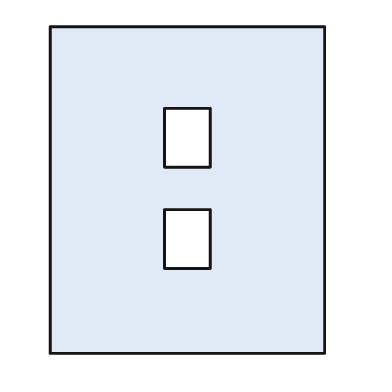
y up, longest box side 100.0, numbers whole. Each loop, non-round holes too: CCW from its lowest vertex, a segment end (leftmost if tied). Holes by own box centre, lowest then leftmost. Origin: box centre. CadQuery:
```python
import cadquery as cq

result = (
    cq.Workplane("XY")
    .moveTo(-42.0, -50.0)
    .lineTo(42.0, -50.0)
    .lineTo(42.0, 50.0)
    .lineTo(-42.0, 50.0)
    .close()
    .moveTo(-7.0, -24.0)
    .lineTo(7.0, -24.0)
    .lineTo(7.0, -6.0)
    .lineTo(-7.0, -6.0)
    .close()
    .moveTo(-7.0, 7.0)
    .lineTo(7.0, 7.0)
    .lineTo(7.0, 25.0)
    .lineTo(-7.0, 25.0)
    .close()
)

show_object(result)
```